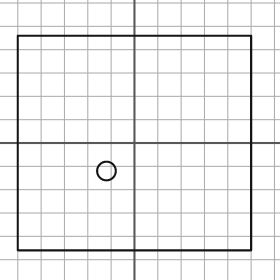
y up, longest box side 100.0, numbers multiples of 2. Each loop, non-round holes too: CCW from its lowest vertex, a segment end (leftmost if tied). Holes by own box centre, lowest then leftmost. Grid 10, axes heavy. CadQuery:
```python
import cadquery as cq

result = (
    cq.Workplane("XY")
    .moveTo(-50.0, -46.0)
    .lineTo(50.0, -46.0)
    .lineTo(50.0, 46.0)
    .lineTo(-50.0, 46.0)
    .close()
    .moveTo(-12.0, -12.0)
    .circle(4.0)
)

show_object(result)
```